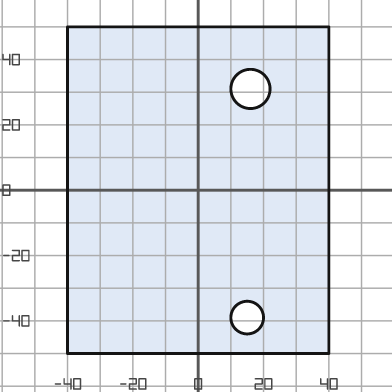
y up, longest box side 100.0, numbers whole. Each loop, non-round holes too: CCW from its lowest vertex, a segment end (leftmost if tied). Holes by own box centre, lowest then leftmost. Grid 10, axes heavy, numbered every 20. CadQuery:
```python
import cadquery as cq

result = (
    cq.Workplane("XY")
    .moveTo(-40.0, -50.0)
    .lineTo(40.0, -50.0)
    .lineTo(40.0, 50.0)
    .lineTo(-40.0, 50.0)
    .close()
    .moveTo(15.0, -39.0)
    .circle(5.0)
    .moveTo(16.0, 31.0)
    .circle(6.0)
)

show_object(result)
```